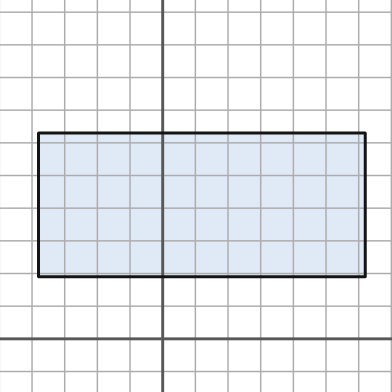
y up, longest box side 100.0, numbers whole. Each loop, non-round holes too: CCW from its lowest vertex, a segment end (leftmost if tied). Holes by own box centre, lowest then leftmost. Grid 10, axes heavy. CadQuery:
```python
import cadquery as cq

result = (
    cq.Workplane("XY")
    .moveTo(-38.0, 19.0)
    .lineTo(62.0, 19.0)
    .lineTo(62.0, 63.0)
    .lineTo(-38.0, 63.0)
    .close()
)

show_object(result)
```